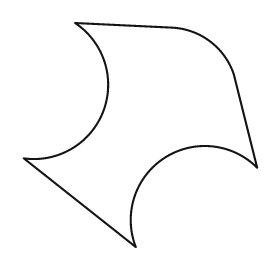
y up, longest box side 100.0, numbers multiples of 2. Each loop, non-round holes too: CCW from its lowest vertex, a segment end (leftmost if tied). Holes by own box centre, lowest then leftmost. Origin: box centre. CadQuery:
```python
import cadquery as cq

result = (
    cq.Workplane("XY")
    .moveTo(-2.0, -48.0)
    .threePointArc((10.0, -10.0), (50.0, -14.0))
    .lineTo(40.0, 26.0)
    .threePointArc((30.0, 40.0), (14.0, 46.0))
    .lineTo(-28.0, 48.0)
    .threePointArc((-16.0, 10.0), (-50.0, -10.0))
    .close()
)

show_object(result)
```